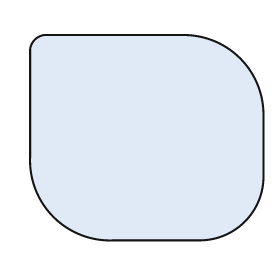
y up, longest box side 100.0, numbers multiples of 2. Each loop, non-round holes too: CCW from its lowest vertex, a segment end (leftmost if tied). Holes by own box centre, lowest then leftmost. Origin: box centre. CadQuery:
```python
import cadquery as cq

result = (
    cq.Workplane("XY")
    .moveTo(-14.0, -44.0)
    .lineTo(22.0, -44.0)
    .threePointArc((42.0, -36.0), (50.0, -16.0))
    .lineTo(50.0, 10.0)
    .threePointArc((40.0, 34.0), (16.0, 44.0))
    .lineTo(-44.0, 44.0)
    .threePointArc((-48.0, 42.0), (-50.0, 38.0))
    .lineTo(-50.0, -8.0)
    .threePointArc((-40.0, -34.0), (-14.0, -44.0))
    .close()
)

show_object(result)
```